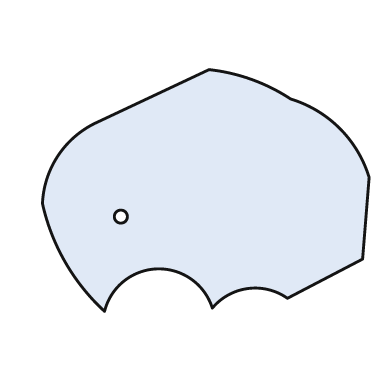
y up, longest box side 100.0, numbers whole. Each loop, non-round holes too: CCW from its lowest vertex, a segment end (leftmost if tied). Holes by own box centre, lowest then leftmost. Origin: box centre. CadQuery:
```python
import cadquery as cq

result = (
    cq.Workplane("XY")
    .moveTo(-31.0, -37.0)
    .threePointArc((-15.0, -24.0), (2.0, -36.0))
    .threePointArc((13.0, -30.0), (25.0, -33.0))
    .lineTo(48.0, -21.0)
    .lineTo(50.0, 4.0)
    .threePointArc((41.0, 19.0), (26.0, 28.0))
    .threePointArc((14.0, 34.0), (1.0, 37.0))
    .lineTo(-33.0, 21.0)
    .threePointArc((-45.0, 11.0), (-50.0, -4.0))
    .threePointArc((-43.0, -22.0), (-31.0, -37.0))
    .close()
    .moveTo(-26.0, -8.0)
    .circle(2.0)
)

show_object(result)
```